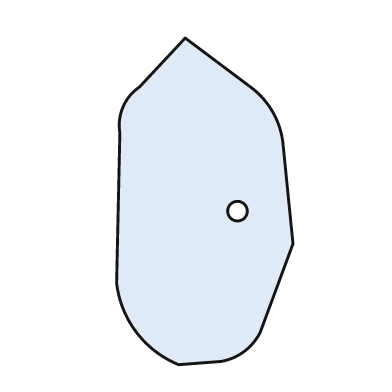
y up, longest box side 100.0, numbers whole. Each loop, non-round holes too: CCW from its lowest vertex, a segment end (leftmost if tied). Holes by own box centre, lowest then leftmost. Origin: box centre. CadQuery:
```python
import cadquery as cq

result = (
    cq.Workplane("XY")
    .moveTo(-8.0, -50.0)
    .lineTo(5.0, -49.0)
    .threePointArc((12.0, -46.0), (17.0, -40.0))
    .lineTo(27.0, -13.0)
    .lineTo(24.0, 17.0)
    .threePointArc((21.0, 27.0), (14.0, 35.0))
    .lineTo(-6.0, 50.0)
    .lineTo(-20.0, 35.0)
    .threePointArc((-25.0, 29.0), (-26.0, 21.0))
    .lineTo(-27.0, -25.0)
    .threePointArc((-21.0, -40.0), (-8.0, -50.0))
    .close()
    .moveTo(10.0, -3.0)
    .circle(3.0)
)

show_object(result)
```